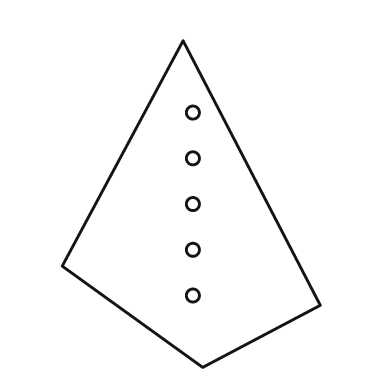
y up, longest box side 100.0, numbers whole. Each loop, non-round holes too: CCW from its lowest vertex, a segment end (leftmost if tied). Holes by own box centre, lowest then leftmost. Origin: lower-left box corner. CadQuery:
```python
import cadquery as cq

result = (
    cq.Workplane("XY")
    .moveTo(43.0, 0.0)
    .lineTo(79.0, 19.0)
    .lineTo(37.0, 100.0)
    .lineTo(0.0, 31.0)
    .close()
    .moveTo(40.0, 22.0)
    .circle(2.0)
    .moveTo(40.0, 36.0)
    .circle(2.0)
    .moveTo(40.0, 50.0)
    .circle(2.0)
    .moveTo(40.0, 64.0)
    .circle(2.0)
    .moveTo(40.0, 78.0)
    .circle(2.0)
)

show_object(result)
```